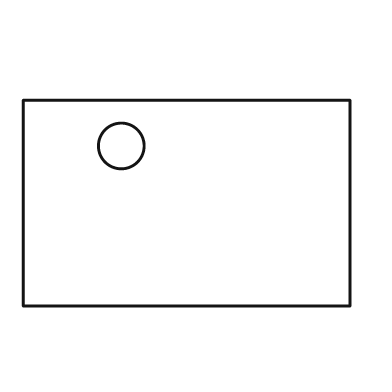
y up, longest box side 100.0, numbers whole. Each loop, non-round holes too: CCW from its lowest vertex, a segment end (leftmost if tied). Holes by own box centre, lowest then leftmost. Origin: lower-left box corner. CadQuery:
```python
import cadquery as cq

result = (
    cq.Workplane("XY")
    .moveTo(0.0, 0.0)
    .lineTo(100.0, 0.0)
    .lineTo(100.0, 63.0)
    .lineTo(0.0, 63.0)
    .close()
    .moveTo(30.0, 49.0)
    .circle(7.0)
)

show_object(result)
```